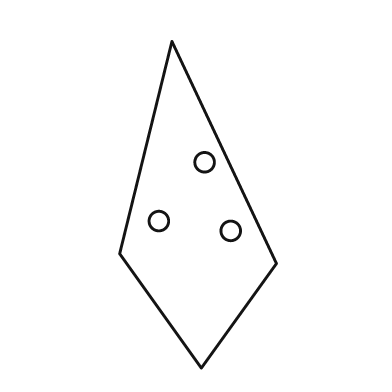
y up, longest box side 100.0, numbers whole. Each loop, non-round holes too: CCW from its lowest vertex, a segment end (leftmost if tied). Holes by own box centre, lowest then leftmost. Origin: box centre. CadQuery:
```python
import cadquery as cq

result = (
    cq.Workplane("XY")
    .moveTo(1.0, -50.0)
    .lineTo(24.0, -18.0)
    .lineTo(-8.0, 50.0)
    .lineTo(-24.0, -15.0)
    .close()
    .moveTo(10.0, -8.0)
    .circle(3.0)
    .moveTo(-12.0, -5.0)
    .circle(3.0)
    .moveTo(2.0, 13.0)
    .circle(3.0)
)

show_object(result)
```